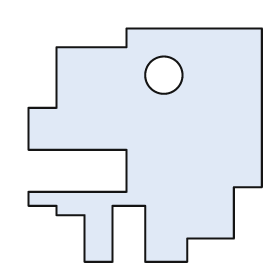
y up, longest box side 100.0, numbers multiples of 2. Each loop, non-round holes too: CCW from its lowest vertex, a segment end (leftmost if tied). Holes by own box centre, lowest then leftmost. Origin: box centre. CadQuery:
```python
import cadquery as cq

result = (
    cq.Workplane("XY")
    .moveTo(-26.0, -50.0)
    .lineTo(-14.0, -50.0)
    .lineTo(-14.0, -26.0)
    .lineTo(0.0, -26.0)
    .lineTo(0.0, -50.0)
    .lineTo(18.0, -50.0)
    .lineTo(18.0, -40.0)
    .lineTo(38.0, -40.0)
    .lineTo(38.0, -18.0)
    .lineTo(50.0, -18.0)
    .lineTo(50.0, 50.0)
    .lineTo(-8.0, 50.0)
    .lineTo(-8.0, 42.0)
    .lineTo(-38.0, 42.0)
    .lineTo(-38.0, 16.0)
    .lineTo(-50.0, 16.0)
    .lineTo(-50.0, -2.0)
    .lineTo(-8.0, -2.0)
    .lineTo(-8.0, -20.0)
    .lineTo(-50.0, -20.0)
    .lineTo(-50.0, -26.0)
    .lineTo(-38.0, -26.0)
    .lineTo(-38.0, -30.0)
    .lineTo(-26.0, -30.0)
    .close()
    .moveTo(8.0, 30.0)
    .circle(8.0)
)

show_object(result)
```